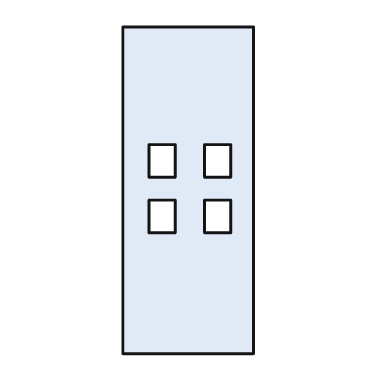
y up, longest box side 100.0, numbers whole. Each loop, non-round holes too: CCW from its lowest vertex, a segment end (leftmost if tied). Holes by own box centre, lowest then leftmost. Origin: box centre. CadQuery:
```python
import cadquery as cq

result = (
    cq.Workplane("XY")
    .moveTo(-20.0, -50.0)
    .lineTo(20.0, -50.0)
    .lineTo(20.0, 50.0)
    .lineTo(-20.0, 50.0)
    .close()
    .moveTo(-12.0, -13.0)
    .lineTo(-4.0, -13.0)
    .lineTo(-4.0, -3.0)
    .lineTo(-12.0, -3.0)
    .close()
    .moveTo(5.0, -13.0)
    .lineTo(13.0, -13.0)
    .lineTo(13.0, -3.0)
    .lineTo(5.0, -3.0)
    .close()
    .moveTo(-12.0, 4.0)
    .lineTo(-4.0, 4.0)
    .lineTo(-4.0, 14.0)
    .lineTo(-12.0, 14.0)
    .close()
    .moveTo(5.0, 4.0)
    .lineTo(13.0, 4.0)
    .lineTo(13.0, 14.0)
    .lineTo(5.0, 14.0)
    .close()
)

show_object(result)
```